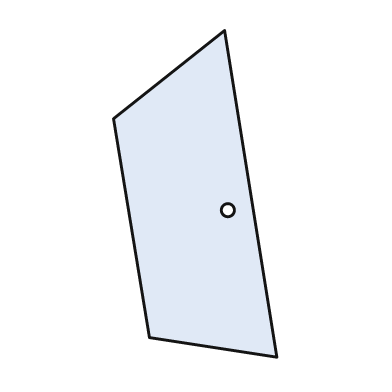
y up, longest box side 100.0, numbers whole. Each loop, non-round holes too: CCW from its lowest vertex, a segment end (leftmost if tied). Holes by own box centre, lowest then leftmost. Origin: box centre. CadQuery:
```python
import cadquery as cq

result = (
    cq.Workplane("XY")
    .moveTo(25.0, -50.0)
    .lineTo(9.0, 50.0)
    .lineTo(-25.0, 23.0)
    .lineTo(-14.0, -44.0)
    .close()
    .moveTo(10.0, -5.0)
    .circle(2.0)
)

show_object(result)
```